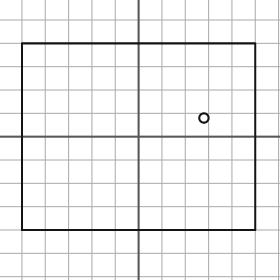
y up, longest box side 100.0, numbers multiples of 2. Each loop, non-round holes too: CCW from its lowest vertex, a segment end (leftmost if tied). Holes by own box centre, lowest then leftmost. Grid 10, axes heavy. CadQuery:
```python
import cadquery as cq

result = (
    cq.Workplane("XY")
    .moveTo(-50.0, -40.0)
    .lineTo(50.0, -40.0)
    .lineTo(50.0, 40.0)
    .lineTo(-50.0, 40.0)
    .close()
    .moveTo(28.0, 8.0)
    .circle(2.0)
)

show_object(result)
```